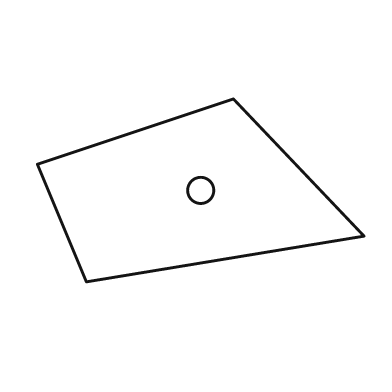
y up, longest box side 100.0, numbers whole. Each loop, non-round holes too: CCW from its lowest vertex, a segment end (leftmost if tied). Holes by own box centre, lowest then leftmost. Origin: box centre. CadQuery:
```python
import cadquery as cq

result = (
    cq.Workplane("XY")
    .moveTo(-35.0, -28.0)
    .lineTo(50.0, -14.0)
    .lineTo(10.0, 28.0)
    .lineTo(-50.0, 8.0)
    .close()
    .moveTo(0.0, 0.0)
    .circle(4.0)
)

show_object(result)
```